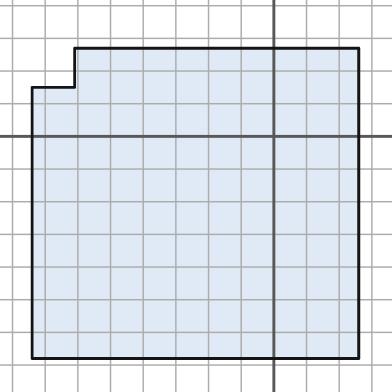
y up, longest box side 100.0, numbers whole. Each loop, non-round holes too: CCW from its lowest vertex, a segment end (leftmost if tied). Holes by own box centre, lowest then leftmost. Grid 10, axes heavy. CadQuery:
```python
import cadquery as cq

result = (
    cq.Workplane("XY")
    .moveTo(-74.0, -68.0)
    .lineTo(26.0, -68.0)
    .lineTo(26.0, 27.0)
    .lineTo(-61.0, 27.0)
    .lineTo(-61.0, 15.0)
    .lineTo(-74.0, 15.0)
    .close()
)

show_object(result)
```